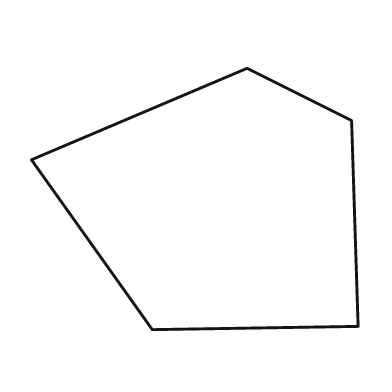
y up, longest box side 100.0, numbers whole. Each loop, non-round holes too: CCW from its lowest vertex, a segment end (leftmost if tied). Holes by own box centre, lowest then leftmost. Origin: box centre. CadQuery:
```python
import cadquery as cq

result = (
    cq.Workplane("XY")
    .moveTo(-13.0, -40.0)
    .lineTo(50.0, -39.0)
    .lineTo(48.0, 24.0)
    .lineTo(16.0, 40.0)
    .lineTo(-50.0, 12.0)
    .close()
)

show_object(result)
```